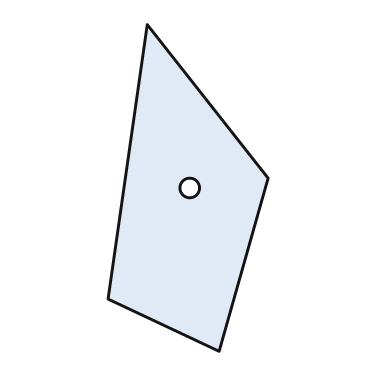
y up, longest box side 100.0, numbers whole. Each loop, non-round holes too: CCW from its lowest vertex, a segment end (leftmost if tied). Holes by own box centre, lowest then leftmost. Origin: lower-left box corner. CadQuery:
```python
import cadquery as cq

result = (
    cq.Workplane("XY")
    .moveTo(34.0, 0.0)
    .lineTo(49.0, 53.0)
    .lineTo(12.0, 100.0)
    .lineTo(0.0, 16.0)
    .close()
    .moveTo(25.0, 50.0)
    .circle(3.0)
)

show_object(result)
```